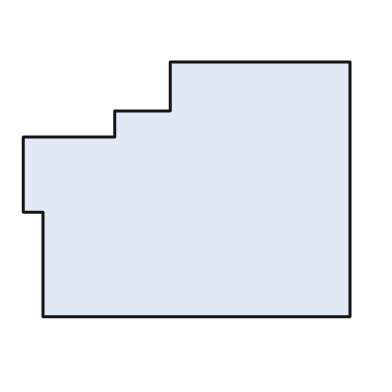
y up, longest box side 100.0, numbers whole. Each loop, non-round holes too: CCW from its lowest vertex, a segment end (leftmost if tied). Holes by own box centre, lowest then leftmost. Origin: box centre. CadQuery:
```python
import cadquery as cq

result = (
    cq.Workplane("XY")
    .moveTo(-44.0, -39.0)
    .lineTo(50.0, -39.0)
    .lineTo(50.0, 39.0)
    .lineTo(-5.0, 39.0)
    .lineTo(-5.0, 24.0)
    .lineTo(-22.0, 24.0)
    .lineTo(-22.0, 16.0)
    .lineTo(-50.0, 16.0)
    .lineTo(-50.0, -7.0)
    .lineTo(-44.0, -7.0)
    .close()
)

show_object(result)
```